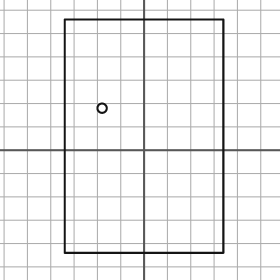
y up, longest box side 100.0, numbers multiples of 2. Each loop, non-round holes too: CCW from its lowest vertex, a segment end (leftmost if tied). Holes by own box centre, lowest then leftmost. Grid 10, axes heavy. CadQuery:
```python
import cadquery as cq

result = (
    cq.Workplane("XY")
    .moveTo(-34.0, -44.0)
    .lineTo(34.0, -44.0)
    .lineTo(34.0, 56.0)
    .lineTo(-34.0, 56.0)
    .close()
    .moveTo(-18.0, 18.0)
    .circle(2.0)
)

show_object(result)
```